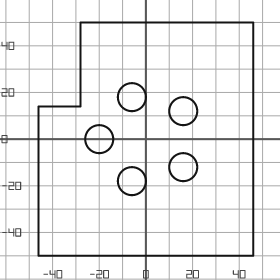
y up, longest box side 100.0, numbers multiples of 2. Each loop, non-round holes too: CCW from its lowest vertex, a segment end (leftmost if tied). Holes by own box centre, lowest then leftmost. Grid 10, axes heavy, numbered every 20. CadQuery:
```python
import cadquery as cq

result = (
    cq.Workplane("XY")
    .moveTo(-46.0, -50.0)
    .lineTo(46.0, -50.0)
    .lineTo(46.0, 50.0)
    .lineTo(-28.0, 50.0)
    .lineTo(-28.0, 14.0)
    .lineTo(-46.0, 14.0)
    .close()
    .moveTo(-6.0, -18.0)
    .circle(6.0)
    .moveTo(16.0, -12.0)
    .circle(6.0)
    .moveTo(-20.0, 0.0)
    .circle(6.0)
    .moveTo(16.0, 12.0)
    .circle(6.0)
    .moveTo(-6.0, 18.0)
    .circle(6.0)
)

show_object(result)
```